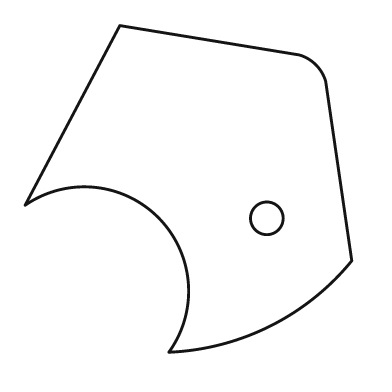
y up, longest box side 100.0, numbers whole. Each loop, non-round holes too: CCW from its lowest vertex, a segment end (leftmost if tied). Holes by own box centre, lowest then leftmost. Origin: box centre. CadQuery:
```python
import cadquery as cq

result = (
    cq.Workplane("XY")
    .moveTo(-6.0, -50.0)
    .threePointArc((25.0, -42.0), (50.0, -22.0))
    .lineTo(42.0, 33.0)
    .threePointArc((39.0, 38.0), (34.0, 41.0))
    .lineTo(-21.0, 50.0)
    .lineTo(-50.0, -5.0)
    .threePointArc((-9.0, -9.0), (-6.0, -50.0))
    .close()
    .moveTo(24.0, -9.0)
    .circle(5.0)
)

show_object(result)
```